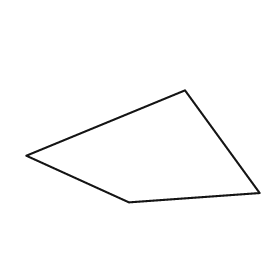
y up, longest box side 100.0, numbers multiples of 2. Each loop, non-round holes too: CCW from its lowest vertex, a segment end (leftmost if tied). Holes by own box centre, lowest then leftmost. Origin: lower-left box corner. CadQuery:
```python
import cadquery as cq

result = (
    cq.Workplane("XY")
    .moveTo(44.0, 0.0)
    .lineTo(100.0, 4.0)
    .lineTo(68.0, 48.0)
    .lineTo(0.0, 20.0)
    .close()
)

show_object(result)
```